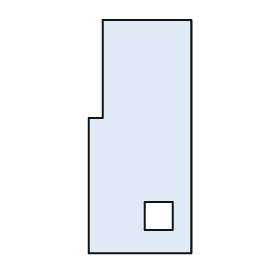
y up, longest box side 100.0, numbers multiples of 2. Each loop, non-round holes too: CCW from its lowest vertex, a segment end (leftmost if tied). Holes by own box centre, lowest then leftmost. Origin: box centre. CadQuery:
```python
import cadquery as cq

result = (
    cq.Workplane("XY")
    .moveTo(-22.0, -50.0)
    .lineTo(22.0, -50.0)
    .lineTo(22.0, 50.0)
    .lineTo(-16.0, 50.0)
    .lineTo(-16.0, 8.0)
    .lineTo(-22.0, 8.0)
    .close()
    .moveTo(2.0, -40.0)
    .lineTo(14.0, -40.0)
    .lineTo(14.0, -28.0)
    .lineTo(2.0, -28.0)
    .close()
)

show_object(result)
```